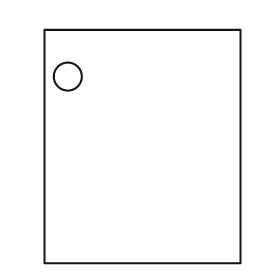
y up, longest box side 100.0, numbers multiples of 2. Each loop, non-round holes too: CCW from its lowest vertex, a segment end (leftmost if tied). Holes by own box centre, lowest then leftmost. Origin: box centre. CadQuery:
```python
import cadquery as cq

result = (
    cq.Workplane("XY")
    .moveTo(-42.0, -50.0)
    .lineTo(42.0, -50.0)
    .lineTo(42.0, 50.0)
    .lineTo(-42.0, 50.0)
    .close()
    .moveTo(-32.0, 30.0)
    .circle(6.0)
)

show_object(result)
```